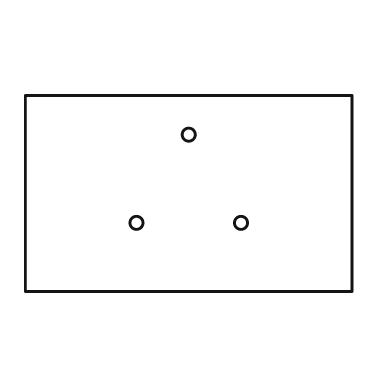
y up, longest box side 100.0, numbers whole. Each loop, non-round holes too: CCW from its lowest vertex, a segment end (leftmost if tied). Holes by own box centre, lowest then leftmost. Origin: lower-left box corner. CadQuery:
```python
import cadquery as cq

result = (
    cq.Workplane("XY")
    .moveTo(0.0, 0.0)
    .lineTo(100.0, 0.0)
    .lineTo(100.0, 60.0)
    .lineTo(0.0, 60.0)
    .close()
    .moveTo(34.0, 21.0)
    .circle(2.0)
    .moveTo(66.0, 21.0)
    .circle(2.0)
    .moveTo(50.0, 48.0)
    .circle(2.0)
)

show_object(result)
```